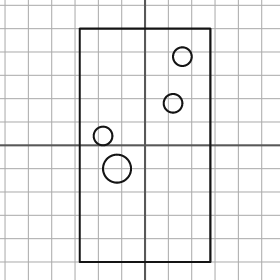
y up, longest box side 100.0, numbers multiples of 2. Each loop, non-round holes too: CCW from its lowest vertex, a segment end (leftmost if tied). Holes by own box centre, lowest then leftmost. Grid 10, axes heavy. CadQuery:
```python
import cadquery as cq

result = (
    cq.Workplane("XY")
    .moveTo(-28.0, -50.0)
    .lineTo(28.0, -50.0)
    .lineTo(28.0, 50.0)
    .lineTo(-28.0, 50.0)
    .close()
    .moveTo(-12.0, -10.0)
    .circle(6.0)
    .moveTo(-18.0, 4.0)
    .circle(4.0)
    .moveTo(12.0, 18.0)
    .circle(4.0)
    .moveTo(16.0, 38.0)
    .circle(4.0)
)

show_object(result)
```